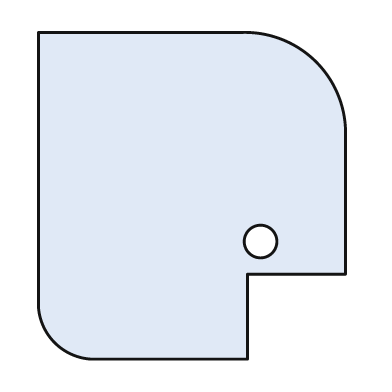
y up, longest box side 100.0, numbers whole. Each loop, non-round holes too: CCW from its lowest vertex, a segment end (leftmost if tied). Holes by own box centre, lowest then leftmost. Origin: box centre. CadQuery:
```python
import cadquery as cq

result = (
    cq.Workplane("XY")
    .moveTo(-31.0, -50.0)
    .lineTo(17.0, -50.0)
    .lineTo(17.0, -24.0)
    .lineTo(47.0, -24.0)
    .lineTo(47.0, 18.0)
    .threePointArc((38.0, 41.0), (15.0, 50.0))
    .lineTo(-47.0, 50.0)
    .lineTo(-47.0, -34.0)
    .threePointArc((-42.0, -45.0), (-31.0, -50.0))
    .close()
    .moveTo(21.0, -14.0)
    .circle(5.0)
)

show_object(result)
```